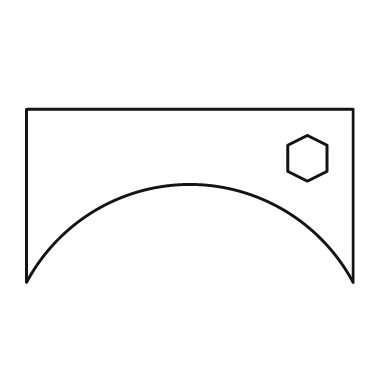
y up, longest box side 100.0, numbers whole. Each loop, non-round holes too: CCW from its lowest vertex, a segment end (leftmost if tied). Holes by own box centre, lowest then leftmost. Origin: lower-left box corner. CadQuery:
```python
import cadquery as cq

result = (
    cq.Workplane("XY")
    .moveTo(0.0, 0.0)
    .threePointArc((50.0, 30.0), (100.0, 0.0))
    .lineTo(100.0, 53.0)
    .lineTo(0.0, 53.0)
    .close()
    .moveTo(86.0, 31.0)
    .lineTo(92.0, 34.0)
    .lineTo(92.0, 42.0)
    .lineTo(86.0, 45.0)
    .lineTo(80.0, 42.0)
    .lineTo(80.0, 34.0)
    .close()
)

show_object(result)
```